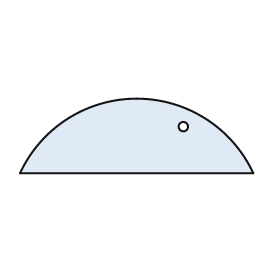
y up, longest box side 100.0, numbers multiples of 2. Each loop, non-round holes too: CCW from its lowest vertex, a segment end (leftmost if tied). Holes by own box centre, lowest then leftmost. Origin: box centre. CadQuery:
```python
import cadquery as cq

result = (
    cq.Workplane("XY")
    .moveTo(-50.0, -16.0)
    .lineTo(50.0, -16.0)
    .threePointArc((0.0, 16.0), (-50.0, -16.0))
    .close()
    .moveTo(20.0, 4.0)
    .circle(2.0)
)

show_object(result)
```